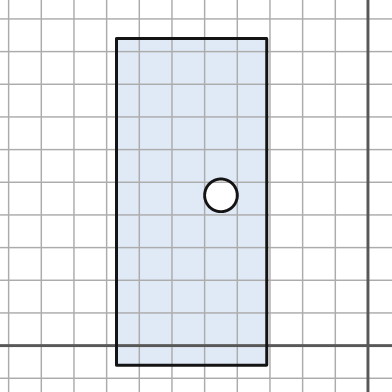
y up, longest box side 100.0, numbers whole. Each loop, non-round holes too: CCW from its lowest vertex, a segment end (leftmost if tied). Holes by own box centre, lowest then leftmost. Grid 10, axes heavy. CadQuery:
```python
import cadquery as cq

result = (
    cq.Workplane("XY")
    .moveTo(-77.0, -6.0)
    .lineTo(-31.0, -6.0)
    .lineTo(-31.0, 94.0)
    .lineTo(-77.0, 94.0)
    .close()
    .moveTo(-45.0, 46.0)
    .circle(5.0)
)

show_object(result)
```